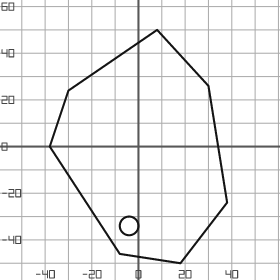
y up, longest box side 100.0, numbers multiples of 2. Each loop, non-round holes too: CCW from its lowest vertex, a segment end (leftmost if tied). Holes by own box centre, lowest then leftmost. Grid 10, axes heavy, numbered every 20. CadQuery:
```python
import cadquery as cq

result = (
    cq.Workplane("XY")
    .moveTo(18.0, -50.0)
    .lineTo(38.0, -24.0)
    .lineTo(30.0, 26.0)
    .lineTo(8.0, 50.0)
    .lineTo(-30.0, 24.0)
    .lineTo(-38.0, 0.0)
    .lineTo(-8.0, -46.0)
    .close()
    .moveTo(-4.0, -34.0)
    .circle(4.0)
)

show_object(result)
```